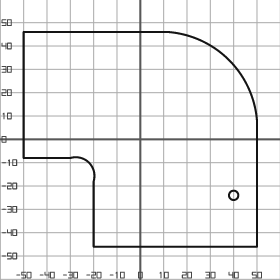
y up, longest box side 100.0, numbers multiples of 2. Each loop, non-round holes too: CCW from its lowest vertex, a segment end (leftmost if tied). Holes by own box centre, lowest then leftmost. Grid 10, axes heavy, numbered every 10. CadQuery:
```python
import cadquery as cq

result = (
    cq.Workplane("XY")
    .moveTo(-20.0, -46.0)
    .lineTo(50.0, -46.0)
    .lineTo(50.0, 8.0)
    .threePointArc((38.0, 34.0), (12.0, 46.0))
    .lineTo(-50.0, 46.0)
    .lineTo(-50.0, -8.0)
    .lineTo(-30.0, -8.0)
    .threePointArc((-22.0, -10.0), (-20.0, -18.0))
    .close()
    .moveTo(40.0, -24.0)
    .circle(2.0)
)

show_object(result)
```